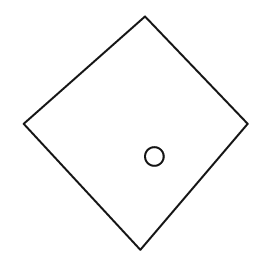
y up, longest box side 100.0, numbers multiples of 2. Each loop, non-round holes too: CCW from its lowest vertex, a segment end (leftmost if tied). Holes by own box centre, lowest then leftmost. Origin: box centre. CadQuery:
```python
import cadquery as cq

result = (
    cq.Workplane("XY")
    .moveTo(2.0, -50.0)
    .lineTo(48.0, 4.0)
    .lineTo(4.0, 50.0)
    .lineTo(-48.0, 4.0)
    .close()
    .moveTo(8.0, -10.0)
    .circle(4.0)
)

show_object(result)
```